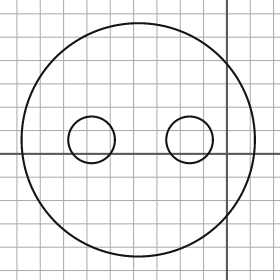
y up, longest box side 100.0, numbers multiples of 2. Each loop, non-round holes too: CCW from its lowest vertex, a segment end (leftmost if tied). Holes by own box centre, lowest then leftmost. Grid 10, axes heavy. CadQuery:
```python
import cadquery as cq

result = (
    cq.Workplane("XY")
    .moveTo(-38.0, 6.0)
    .circle(50.0)
    .moveTo(-58.0, 6.0)
    .circle(10.0)
    .moveTo(-16.0, 6.0)
    .circle(10.0)
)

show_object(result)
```